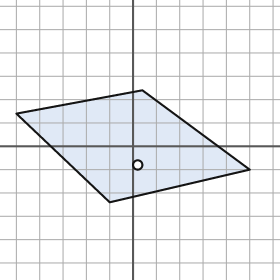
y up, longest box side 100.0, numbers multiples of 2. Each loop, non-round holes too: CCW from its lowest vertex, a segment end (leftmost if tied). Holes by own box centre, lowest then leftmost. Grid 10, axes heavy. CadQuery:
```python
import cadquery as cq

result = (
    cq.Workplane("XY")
    .moveTo(-10.0, -24.0)
    .lineTo(50.0, -10.0)
    .lineTo(4.0, 24.0)
    .lineTo(-50.0, 14.0)
    .close()
    .moveTo(2.0, -8.0)
    .circle(2.0)
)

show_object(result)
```